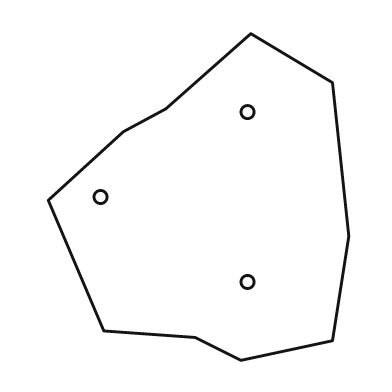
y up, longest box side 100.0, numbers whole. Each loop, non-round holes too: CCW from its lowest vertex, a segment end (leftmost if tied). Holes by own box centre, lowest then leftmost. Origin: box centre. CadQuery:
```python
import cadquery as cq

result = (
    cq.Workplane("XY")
    .moveTo(13.0, -50.0)
    .lineTo(41.0, -44.0)
    .lineTo(46.0, -12.0)
    .lineTo(41.0, 35.0)
    .lineTo(16.0, 50.0)
    .lineTo(-10.0, 27.0)
    .lineTo(-23.0, 20.0)
    .lineTo(-46.0, -1.0)
    .lineTo(-29.0, -41.0)
    .lineTo(-1.0, -43.0)
    .close()
    .moveTo(15.0, -26.0)
    .circle(2.0)
    .moveTo(-30.0, 0.0)
    .circle(2.0)
    .moveTo(15.0, 26.0)
    .circle(2.0)
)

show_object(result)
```